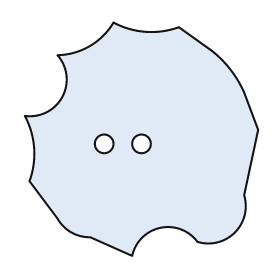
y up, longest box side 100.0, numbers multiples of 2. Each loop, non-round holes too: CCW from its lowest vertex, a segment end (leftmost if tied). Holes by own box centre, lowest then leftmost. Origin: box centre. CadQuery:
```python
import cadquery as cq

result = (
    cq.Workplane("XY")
    .moveTo(-4.0, -50.0)
    .threePointArc((8.0, -38.0), (24.0, -44.0))
    .threePointArc((40.0, -40.0), (44.0, -24.0))
    .lineTo(50.0, 4.0)
    .lineTo(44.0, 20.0)
    .threePointArc((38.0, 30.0), (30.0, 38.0))
    .lineTo(16.0, 48.0)
    .threePointArc((2.0, 46.0), (-12.0, 50.0))
    .threePointArc((-22.0, 40.0), (-36.0, 36.0))
    .threePointArc((-34.0, 18.0), (-50.0, 10.0))
    .threePointArc((-46.0, -4.0), (-48.0, -18.0))
    .lineTo(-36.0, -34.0)
    .threePointArc((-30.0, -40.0), (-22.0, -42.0))
    .close()
    .moveTo(-16.0, -2.0)
    .circle(4.0)
    .moveTo(0.0, -2.0)
    .circle(4.0)
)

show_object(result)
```